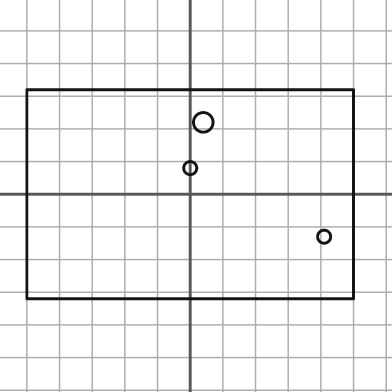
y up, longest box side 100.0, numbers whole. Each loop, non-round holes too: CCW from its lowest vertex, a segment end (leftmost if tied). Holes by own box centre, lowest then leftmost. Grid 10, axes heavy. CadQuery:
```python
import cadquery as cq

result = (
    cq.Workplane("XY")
    .moveTo(-50.0, -32.0)
    .lineTo(50.0, -32.0)
    .lineTo(50.0, 32.0)
    .lineTo(-50.0, 32.0)
    .close()
    .moveTo(41.0, -13.0)
    .circle(2.0)
    .moveTo(0.0, 8.0)
    .circle(2.0)
    .moveTo(4.0, 22.0)
    .circle(3.0)
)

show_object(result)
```